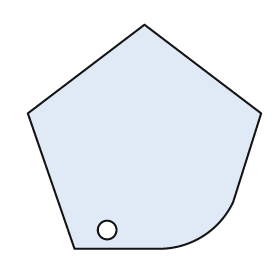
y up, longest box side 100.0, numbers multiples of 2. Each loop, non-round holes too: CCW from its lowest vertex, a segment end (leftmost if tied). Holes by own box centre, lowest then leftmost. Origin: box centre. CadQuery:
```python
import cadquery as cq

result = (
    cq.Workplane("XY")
    .moveTo(-30.0, -48.0)
    .lineTo(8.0, -48.0)
    .threePointArc((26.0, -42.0), (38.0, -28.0))
    .lineTo(50.0, 10.0)
    .lineTo(0.0, 48.0)
    .lineTo(-50.0, 10.0)
    .close()
    .moveTo(-16.0, -40.0)
    .circle(4.0)
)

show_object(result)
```